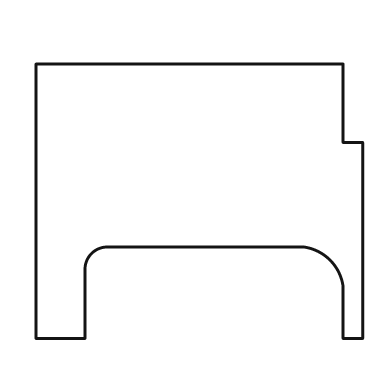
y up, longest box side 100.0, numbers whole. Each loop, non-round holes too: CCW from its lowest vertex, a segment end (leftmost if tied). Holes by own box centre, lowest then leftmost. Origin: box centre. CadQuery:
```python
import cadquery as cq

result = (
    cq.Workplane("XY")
    .moveTo(-50.0, -42.0)
    .lineTo(-35.0, -42.0)
    .lineTo(-35.0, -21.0)
    .threePointArc((-33.0, -16.0), (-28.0, -14.0))
    .lineTo(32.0, -14.0)
    .threePointArc((40.0, -18.0), (44.0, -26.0))
    .lineTo(44.0, -42.0)
    .lineTo(50.0, -42.0)
    .lineTo(50.0, 18.0)
    .lineTo(44.0, 18.0)
    .lineTo(44.0, 42.0)
    .lineTo(-50.0, 42.0)
    .close()
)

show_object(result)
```